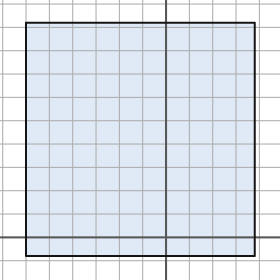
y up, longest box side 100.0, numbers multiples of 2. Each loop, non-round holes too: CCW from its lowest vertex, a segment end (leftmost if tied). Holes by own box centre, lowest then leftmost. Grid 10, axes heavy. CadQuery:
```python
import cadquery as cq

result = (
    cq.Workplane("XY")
    .moveTo(-60.0, -8.0)
    .lineTo(38.0, -8.0)
    .lineTo(38.0, 92.0)
    .lineTo(-60.0, 92.0)
    .close()
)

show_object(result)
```